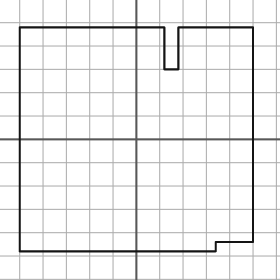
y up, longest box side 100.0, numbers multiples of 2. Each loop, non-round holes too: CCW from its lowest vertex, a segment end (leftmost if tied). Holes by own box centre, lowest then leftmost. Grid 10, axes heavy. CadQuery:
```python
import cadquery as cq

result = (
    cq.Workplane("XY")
    .moveTo(-50.0, -48.0)
    .lineTo(34.0, -48.0)
    .lineTo(34.0, -44.0)
    .lineTo(50.0, -44.0)
    .lineTo(50.0, 48.0)
    .lineTo(18.0, 48.0)
    .lineTo(18.0, 30.0)
    .lineTo(12.0, 30.0)
    .lineTo(12.0, 48.0)
    .lineTo(-50.0, 48.0)
    .close()
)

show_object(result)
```